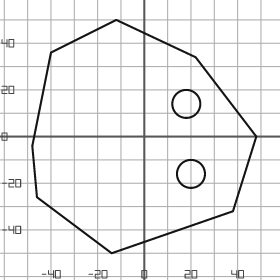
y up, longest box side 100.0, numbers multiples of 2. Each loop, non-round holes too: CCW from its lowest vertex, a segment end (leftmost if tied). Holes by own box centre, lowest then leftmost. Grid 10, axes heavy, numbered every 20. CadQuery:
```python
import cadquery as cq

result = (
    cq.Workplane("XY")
    .moveTo(-14.0, -50.0)
    .lineTo(38.0, -32.0)
    .lineTo(48.0, 0.0)
    .lineTo(22.0, 34.0)
    .lineTo(-12.0, 50.0)
    .lineTo(-40.0, 36.0)
    .lineTo(-48.0, -4.0)
    .lineTo(-46.0, -26.0)
    .close()
    .moveTo(20.0, -16.0)
    .circle(6.0)
    .moveTo(18.0, 14.0)
    .circle(6.0)
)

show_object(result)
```